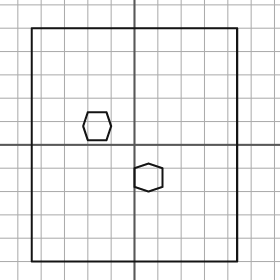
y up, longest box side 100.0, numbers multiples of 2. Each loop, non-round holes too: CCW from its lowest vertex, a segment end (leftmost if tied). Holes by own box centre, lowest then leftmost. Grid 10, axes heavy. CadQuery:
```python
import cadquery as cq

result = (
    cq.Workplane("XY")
    .moveTo(-44.0, -50.0)
    .lineTo(44.0, -50.0)
    .lineTo(44.0, 50.0)
    .lineTo(-44.0, 50.0)
    .close()
    .moveTo(6.0, -20.0)
    .lineTo(12.0, -18.0)
    .lineTo(12.0, -10.0)
    .lineTo(6.0, -8.0)
    .lineTo(0.0, -10.0)
    .lineTo(0.0, -18.0)
    .close()
    .moveTo(-20.0, 2.0)
    .lineTo(-12.0, 2.0)
    .lineTo(-10.0, 8.0)
    .lineTo(-12.0, 14.0)
    .lineTo(-20.0, 14.0)
    .lineTo(-22.0, 8.0)
    .close()
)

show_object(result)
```